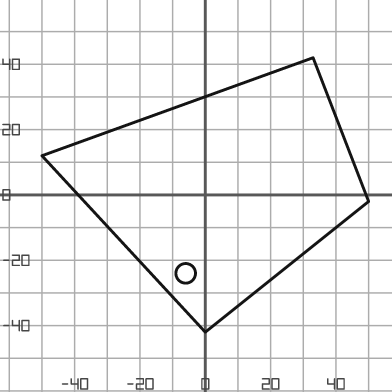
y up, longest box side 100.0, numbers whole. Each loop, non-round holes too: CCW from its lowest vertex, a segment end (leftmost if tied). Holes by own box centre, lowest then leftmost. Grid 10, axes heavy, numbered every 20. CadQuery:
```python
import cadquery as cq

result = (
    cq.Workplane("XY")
    .moveTo(0.0, -42.0)
    .lineTo(50.0, -2.0)
    .lineTo(33.0, 42.0)
    .lineTo(-50.0, 12.0)
    .close()
    .moveTo(-6.0, -24.0)
    .circle(3.0)
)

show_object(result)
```